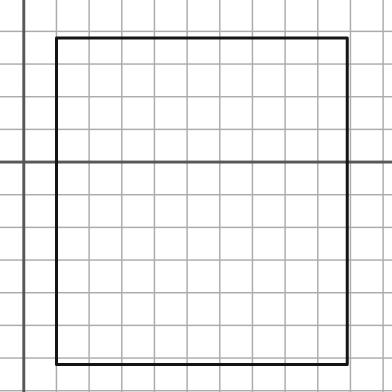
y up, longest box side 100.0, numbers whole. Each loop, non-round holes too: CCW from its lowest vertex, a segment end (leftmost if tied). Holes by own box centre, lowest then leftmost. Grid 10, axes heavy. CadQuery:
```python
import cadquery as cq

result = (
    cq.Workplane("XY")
    .moveTo(10.0, -62.0)
    .lineTo(99.0, -62.0)
    .lineTo(99.0, 38.0)
    .lineTo(10.0, 38.0)
    .close()
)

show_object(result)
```